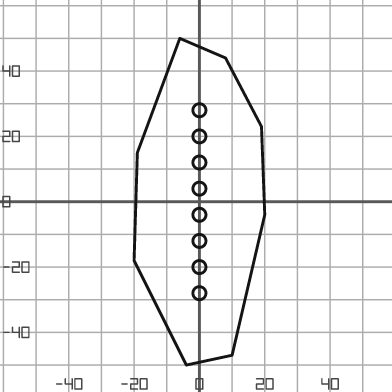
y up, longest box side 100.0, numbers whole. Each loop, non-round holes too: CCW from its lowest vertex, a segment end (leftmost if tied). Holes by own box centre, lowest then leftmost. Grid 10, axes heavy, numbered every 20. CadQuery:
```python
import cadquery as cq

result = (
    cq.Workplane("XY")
    .moveTo(-4.0, -50.0)
    .lineTo(10.0, -47.0)
    .lineTo(20.0, -4.0)
    .lineTo(19.0, 23.0)
    .lineTo(8.0, 44.0)
    .lineTo(-6.0, 50.0)
    .lineTo(-19.0, 15.0)
    .lineTo(-20.0, -18.0)
    .close()
    .moveTo(0.0, -28.0)
    .circle(2.0)
    .moveTo(0.0, -20.0)
    .circle(2.0)
    .moveTo(0.0, -12.0)
    .circle(2.0)
    .moveTo(0.0, -4.0)
    .circle(2.0)
    .moveTo(0.0, 4.0)
    .circle(2.0)
    .moveTo(0.0, 12.0)
    .circle(2.0)
    .moveTo(0.0, 20.0)
    .circle(2.0)
    .moveTo(0.0, 28.0)
    .circle(2.0)
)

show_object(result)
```